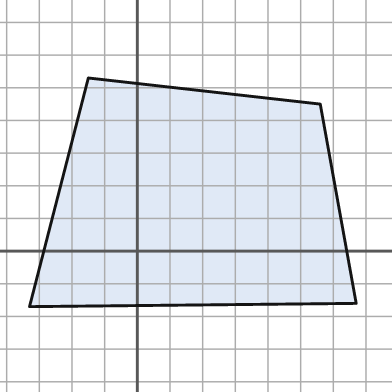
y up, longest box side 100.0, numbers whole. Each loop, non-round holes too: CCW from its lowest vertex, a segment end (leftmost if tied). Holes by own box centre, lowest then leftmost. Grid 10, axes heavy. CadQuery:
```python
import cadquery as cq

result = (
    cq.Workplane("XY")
    .moveTo(-33.0, -17.0)
    .lineTo(67.0, -16.0)
    .lineTo(56.0, 45.0)
    .lineTo(-15.0, 53.0)
    .close()
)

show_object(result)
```